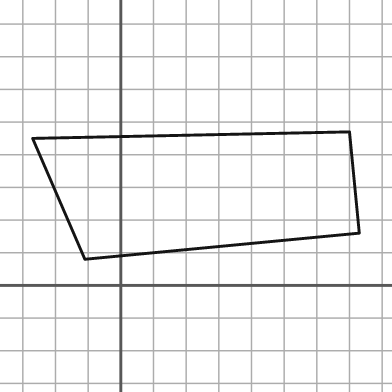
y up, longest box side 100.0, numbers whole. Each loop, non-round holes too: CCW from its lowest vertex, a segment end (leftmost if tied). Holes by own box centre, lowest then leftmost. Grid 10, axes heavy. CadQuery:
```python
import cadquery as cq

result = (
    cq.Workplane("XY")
    .moveTo(-11.0, 8.0)
    .lineTo(73.0, 16.0)
    .lineTo(70.0, 47.0)
    .lineTo(-27.0, 45.0)
    .close()
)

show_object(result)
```